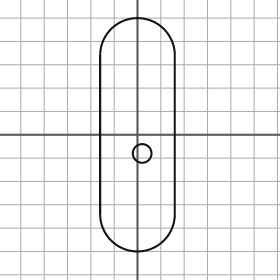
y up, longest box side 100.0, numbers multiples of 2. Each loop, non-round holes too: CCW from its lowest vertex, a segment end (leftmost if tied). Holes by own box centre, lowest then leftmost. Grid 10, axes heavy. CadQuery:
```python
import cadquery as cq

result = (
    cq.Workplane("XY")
    .moveTo(-16.0, -34.0)
    .threePointArc((0.0, -50.0), (16.0, -34.0))
    .lineTo(16.0, 34.0)
    .threePointArc((0.0, 50.0), (-16.0, 34.0))
    .close()
    .moveTo(2.0, -8.0)
    .circle(4.0)
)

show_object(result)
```